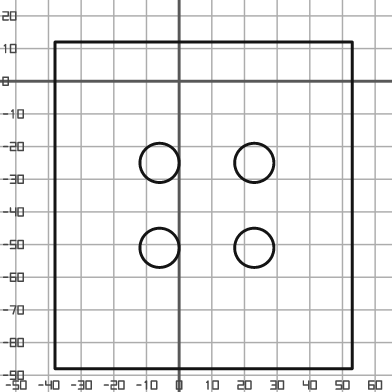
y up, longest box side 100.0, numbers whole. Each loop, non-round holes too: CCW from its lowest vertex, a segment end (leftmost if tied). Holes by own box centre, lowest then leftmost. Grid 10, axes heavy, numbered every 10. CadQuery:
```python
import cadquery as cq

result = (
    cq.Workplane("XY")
    .moveTo(-38.0, -88.0)
    .lineTo(53.0, -88.0)
    .lineTo(53.0, 12.0)
    .lineTo(-38.0, 12.0)
    .close()
    .moveTo(-6.0, -51.0)
    .circle(6.0)
    .moveTo(23.0, -51.0)
    .circle(6.0)
    .moveTo(-6.0, -25.0)
    .circle(6.0)
    .moveTo(23.0, -25.0)
    .circle(6.0)
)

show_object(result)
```